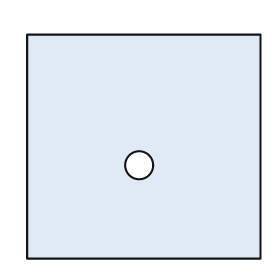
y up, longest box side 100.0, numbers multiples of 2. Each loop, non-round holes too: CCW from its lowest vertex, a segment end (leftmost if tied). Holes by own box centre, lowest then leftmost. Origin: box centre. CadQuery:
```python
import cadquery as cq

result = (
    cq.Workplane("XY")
    .moveTo(-50.0, -48.0)
    .lineTo(50.0, -48.0)
    .lineTo(50.0, 48.0)
    .lineTo(-50.0, 48.0)
    .close()
    .moveTo(-2.0, -8.0)
    .circle(6.0)
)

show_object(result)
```